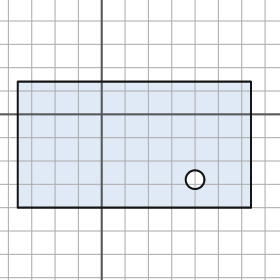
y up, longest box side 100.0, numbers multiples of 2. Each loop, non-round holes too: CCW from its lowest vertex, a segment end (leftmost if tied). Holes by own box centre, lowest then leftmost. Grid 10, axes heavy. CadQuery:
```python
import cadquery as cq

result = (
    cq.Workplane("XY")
    .moveTo(-36.0, -40.0)
    .lineTo(64.0, -40.0)
    .lineTo(64.0, 14.0)
    .lineTo(-36.0, 14.0)
    .close()
    .moveTo(40.0, -28.0)
    .circle(4.0)
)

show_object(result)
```